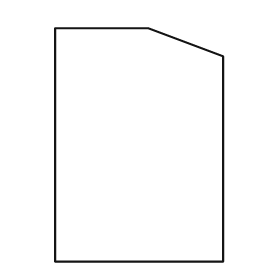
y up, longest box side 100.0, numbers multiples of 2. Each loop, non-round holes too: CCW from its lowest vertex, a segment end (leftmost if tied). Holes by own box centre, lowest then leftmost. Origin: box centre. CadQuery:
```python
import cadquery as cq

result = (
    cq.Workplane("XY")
    .moveTo(-36.0, -50.0)
    .lineTo(36.0, -50.0)
    .lineTo(36.0, 38.0)
    .lineTo(4.0, 50.0)
    .lineTo(-36.0, 50.0)
    .close()
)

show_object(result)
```